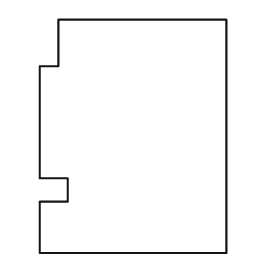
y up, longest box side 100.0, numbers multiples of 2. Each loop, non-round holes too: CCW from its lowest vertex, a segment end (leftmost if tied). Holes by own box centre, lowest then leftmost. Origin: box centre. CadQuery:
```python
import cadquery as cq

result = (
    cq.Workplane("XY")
    .moveTo(-40.0, -50.0)
    .lineTo(40.0, -50.0)
    .lineTo(40.0, 50.0)
    .lineTo(-32.0, 50.0)
    .lineTo(-32.0, 30.0)
    .lineTo(-40.0, 30.0)
    .lineTo(-40.0, -18.0)
    .lineTo(-28.0, -18.0)
    .lineTo(-28.0, -28.0)
    .lineTo(-40.0, -28.0)
    .close()
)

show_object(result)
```